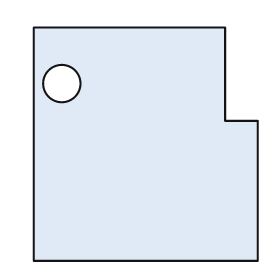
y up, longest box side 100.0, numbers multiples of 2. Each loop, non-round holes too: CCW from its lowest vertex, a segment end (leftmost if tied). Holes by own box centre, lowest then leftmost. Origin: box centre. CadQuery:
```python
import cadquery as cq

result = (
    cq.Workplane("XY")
    .moveTo(-48.0, -50.0)
    .lineTo(48.0, -50.0)
    .lineTo(48.0, 10.0)
    .lineTo(34.0, 10.0)
    .lineTo(34.0, 50.0)
    .lineTo(-48.0, 50.0)
    .close()
    .moveTo(-36.0, 26.0)
    .circle(8.0)
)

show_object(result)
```